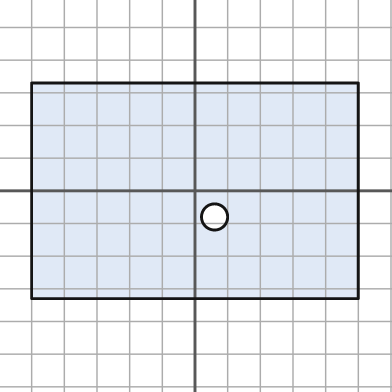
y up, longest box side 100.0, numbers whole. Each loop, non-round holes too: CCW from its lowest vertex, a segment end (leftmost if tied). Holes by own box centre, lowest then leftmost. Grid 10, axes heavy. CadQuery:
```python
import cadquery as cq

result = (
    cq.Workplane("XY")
    .moveTo(-50.0, -33.0)
    .lineTo(50.0, -33.0)
    .lineTo(50.0, 33.0)
    .lineTo(-50.0, 33.0)
    .close()
    .moveTo(6.0, -8.0)
    .circle(4.0)
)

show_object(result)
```